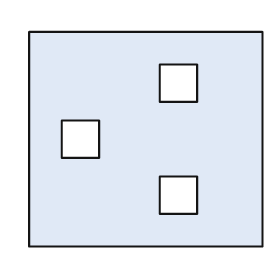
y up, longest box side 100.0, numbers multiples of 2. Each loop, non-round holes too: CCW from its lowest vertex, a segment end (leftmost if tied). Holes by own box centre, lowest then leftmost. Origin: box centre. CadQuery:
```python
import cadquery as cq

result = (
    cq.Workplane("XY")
    .moveTo(-50.0, -46.0)
    .lineTo(50.0, -46.0)
    .lineTo(50.0, 46.0)
    .lineTo(-50.0, 46.0)
    .close()
    .moveTo(6.0, -32.0)
    .lineTo(22.0, -32.0)
    .lineTo(22.0, -16.0)
    .lineTo(6.0, -16.0)
    .close()
    .moveTo(-36.0, -8.0)
    .lineTo(-20.0, -8.0)
    .lineTo(-20.0, 8.0)
    .lineTo(-36.0, 8.0)
    .close()
    .moveTo(6.0, 16.0)
    .lineTo(22.0, 16.0)
    .lineTo(22.0, 32.0)
    .lineTo(6.0, 32.0)
    .close()
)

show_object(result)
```